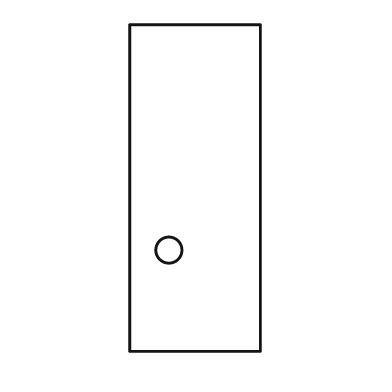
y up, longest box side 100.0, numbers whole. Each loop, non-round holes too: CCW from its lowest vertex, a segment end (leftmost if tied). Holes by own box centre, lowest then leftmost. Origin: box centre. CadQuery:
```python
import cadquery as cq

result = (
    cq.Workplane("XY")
    .moveTo(-20.0, -50.0)
    .lineTo(20.0, -50.0)
    .lineTo(20.0, 50.0)
    .lineTo(-20.0, 50.0)
    .close()
    .moveTo(-8.0, -19.0)
    .circle(4.0)
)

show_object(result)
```